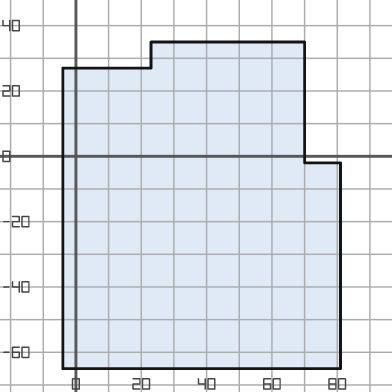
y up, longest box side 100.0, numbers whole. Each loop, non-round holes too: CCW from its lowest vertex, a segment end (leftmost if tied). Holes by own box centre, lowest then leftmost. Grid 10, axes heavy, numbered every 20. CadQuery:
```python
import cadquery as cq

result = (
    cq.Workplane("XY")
    .moveTo(-4.0, -65.0)
    .lineTo(81.0, -65.0)
    .lineTo(81.0, -2.0)
    .lineTo(70.0, -2.0)
    .lineTo(70.0, 35.0)
    .lineTo(23.0, 35.0)
    .lineTo(23.0, 27.0)
    .lineTo(-4.0, 27.0)
    .close()
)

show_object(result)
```